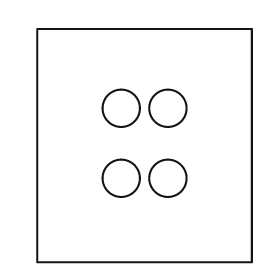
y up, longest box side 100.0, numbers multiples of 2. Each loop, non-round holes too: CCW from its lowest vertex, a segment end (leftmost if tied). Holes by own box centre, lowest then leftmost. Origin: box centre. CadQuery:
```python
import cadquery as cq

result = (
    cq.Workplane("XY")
    .moveTo(-46.0, -50.0)
    .lineTo(46.0, -50.0)
    .lineTo(46.0, 50.0)
    .lineTo(-46.0, 50.0)
    .close()
    .moveTo(-10.0, -14.0)
    .circle(8.0)
    .moveTo(10.0, -14.0)
    .circle(8.0)
    .moveTo(-10.0, 16.0)
    .circle(8.0)
    .moveTo(10.0, 16.0)
    .circle(8.0)
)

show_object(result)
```